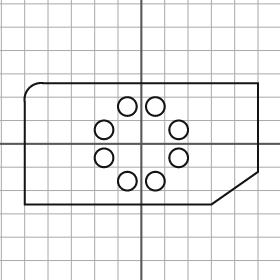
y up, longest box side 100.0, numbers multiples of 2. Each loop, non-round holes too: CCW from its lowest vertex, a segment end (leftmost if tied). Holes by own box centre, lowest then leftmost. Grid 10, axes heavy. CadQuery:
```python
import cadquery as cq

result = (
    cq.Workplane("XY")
    .moveTo(-50.0, -26.0)
    .lineTo(30.0, -26.0)
    .lineTo(50.0, -12.0)
    .lineTo(50.0, 26.0)
    .lineTo(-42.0, 26.0)
    .threePointArc((-48.0, 24.0), (-50.0, 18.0))
    .close()
    .moveTo(-6.0, -16.0)
    .circle(4.0)
    .moveTo(6.0, -16.0)
    .circle(4.0)
    .moveTo(-16.0, -6.0)
    .circle(4.0)
    .moveTo(16.0, -6.0)
    .circle(4.0)
    .moveTo(-16.0, 6.0)
    .circle(4.0)
    .moveTo(16.0, 6.0)
    .circle(4.0)
    .moveTo(-6.0, 16.0)
    .circle(4.0)
    .moveTo(6.0, 16.0)
    .circle(4.0)
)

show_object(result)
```